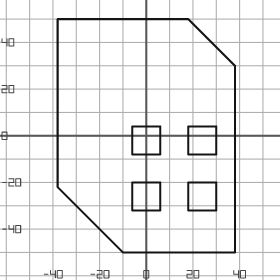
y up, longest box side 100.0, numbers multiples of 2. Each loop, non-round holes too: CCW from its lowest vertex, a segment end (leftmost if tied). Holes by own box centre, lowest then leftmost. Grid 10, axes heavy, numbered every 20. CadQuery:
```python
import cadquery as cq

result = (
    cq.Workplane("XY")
    .moveTo(-10.0, -50.0)
    .lineTo(38.0, -50.0)
    .lineTo(38.0, 30.0)
    .lineTo(18.0, 50.0)
    .lineTo(-38.0, 50.0)
    .lineTo(-38.0, -22.0)
    .close()
    .moveTo(-6.0, -32.0)
    .lineTo(6.0, -32.0)
    .lineTo(6.0, -20.0)
    .lineTo(-6.0, -20.0)
    .close()
    .moveTo(18.0, -32.0)
    .lineTo(30.0, -32.0)
    .lineTo(30.0, -20.0)
    .lineTo(18.0, -20.0)
    .close()
    .moveTo(-6.0, -8.0)
    .lineTo(6.0, -8.0)
    .lineTo(6.0, 4.0)
    .lineTo(-6.0, 4.0)
    .close()
    .moveTo(18.0, -8.0)
    .lineTo(30.0, -8.0)
    .lineTo(30.0, 4.0)
    .lineTo(18.0, 4.0)
    .close()
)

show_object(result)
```